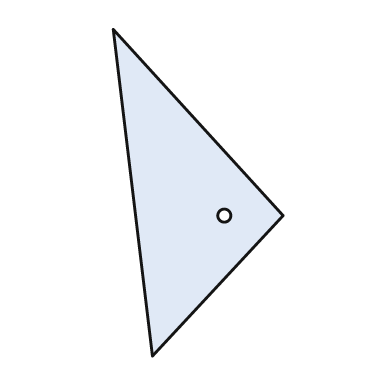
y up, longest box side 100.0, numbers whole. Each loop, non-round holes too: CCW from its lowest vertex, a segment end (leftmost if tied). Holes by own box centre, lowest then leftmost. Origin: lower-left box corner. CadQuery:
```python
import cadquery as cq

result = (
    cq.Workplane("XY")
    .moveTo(12.0, 0.0)
    .lineTo(52.0, 43.0)
    .lineTo(0.0, 100.0)
    .close()
    .moveTo(34.0, 43.0)
    .circle(2.0)
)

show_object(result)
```